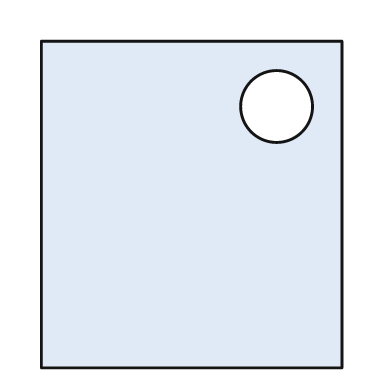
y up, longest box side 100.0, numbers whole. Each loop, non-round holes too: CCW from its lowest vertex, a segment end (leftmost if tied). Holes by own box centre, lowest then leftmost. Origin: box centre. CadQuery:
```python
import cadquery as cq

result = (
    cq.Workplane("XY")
    .moveTo(-46.0, -50.0)
    .lineTo(46.0, -50.0)
    .lineTo(46.0, 50.0)
    .lineTo(-46.0, 50.0)
    .close()
    .moveTo(26.0, 30.0)
    .circle(11.0)
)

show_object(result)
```